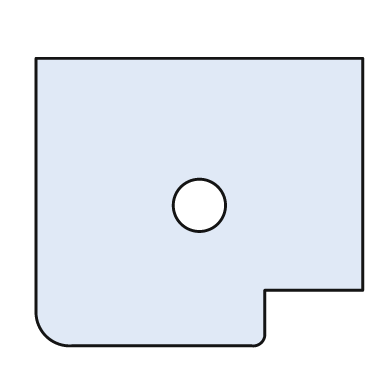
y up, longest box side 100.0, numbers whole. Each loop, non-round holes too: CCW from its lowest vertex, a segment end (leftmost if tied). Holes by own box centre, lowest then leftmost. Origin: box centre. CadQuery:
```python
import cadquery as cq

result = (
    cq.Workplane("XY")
    .moveTo(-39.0, -44.0)
    .lineTo(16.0, -44.0)
    .threePointArc((19.0, -43.0), (20.0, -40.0))
    .lineTo(20.0, -27.0)
    .lineTo(50.0, -27.0)
    .lineTo(50.0, 44.0)
    .lineTo(-50.0, 44.0)
    .lineTo(-50.0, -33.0)
    .threePointArc((-47.0, -41.0), (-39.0, -44.0))
    .close()
    .moveTo(0.0, -1.0)
    .circle(8.0)
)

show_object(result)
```